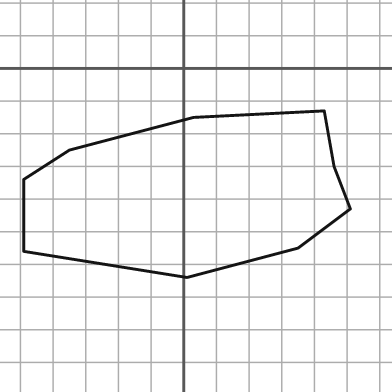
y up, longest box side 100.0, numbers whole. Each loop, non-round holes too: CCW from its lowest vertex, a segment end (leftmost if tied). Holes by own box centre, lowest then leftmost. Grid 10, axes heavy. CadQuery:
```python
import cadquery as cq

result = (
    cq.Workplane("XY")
    .moveTo(1.0, -64.0)
    .lineTo(35.0, -55.0)
    .lineTo(51.0, -43.0)
    .lineTo(46.0, -30.0)
    .lineTo(43.0, -13.0)
    .lineTo(3.0, -15.0)
    .lineTo(-35.0, -25.0)
    .lineTo(-49.0, -34.0)
    .lineTo(-49.0, -56.0)
    .close()
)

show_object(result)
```